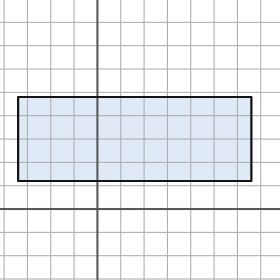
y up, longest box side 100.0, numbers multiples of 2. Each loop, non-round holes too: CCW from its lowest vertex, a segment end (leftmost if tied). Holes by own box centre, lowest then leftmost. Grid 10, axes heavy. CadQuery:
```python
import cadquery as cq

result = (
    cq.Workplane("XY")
    .moveTo(-34.0, 12.0)
    .lineTo(66.0, 12.0)
    .lineTo(66.0, 48.0)
    .lineTo(-34.0, 48.0)
    .close()
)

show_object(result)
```